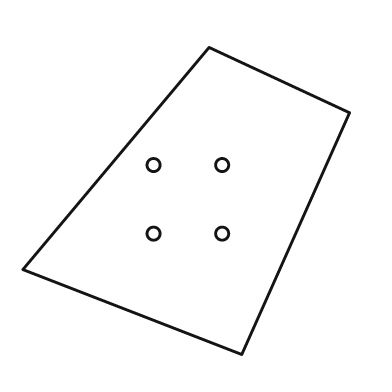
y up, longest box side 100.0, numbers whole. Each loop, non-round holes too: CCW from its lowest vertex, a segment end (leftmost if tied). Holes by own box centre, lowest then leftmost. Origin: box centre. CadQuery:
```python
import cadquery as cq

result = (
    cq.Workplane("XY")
    .moveTo(17.0, -47.0)
    .lineTo(50.0, 27.0)
    .lineTo(7.0, 47.0)
    .lineTo(-50.0, -21.0)
    .close()
    .moveTo(-10.0, -10.0)
    .circle(2.0)
    .moveTo(11.0, -10.0)
    .circle(2.0)
    .moveTo(-10.0, 11.0)
    .circle(2.0)
    .moveTo(11.0, 11.0)
    .circle(2.0)
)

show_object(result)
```